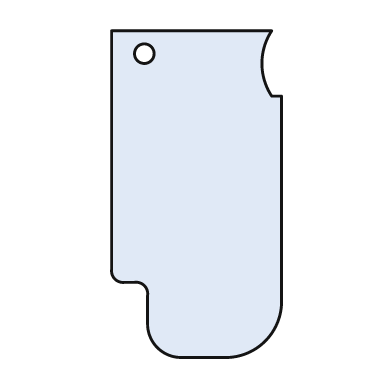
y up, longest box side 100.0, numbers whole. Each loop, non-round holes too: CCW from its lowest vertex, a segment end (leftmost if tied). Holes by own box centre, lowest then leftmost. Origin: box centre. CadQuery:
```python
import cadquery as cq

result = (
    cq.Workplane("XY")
    .moveTo(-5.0, -50.0)
    .lineTo(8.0, -50.0)
    .threePointArc((21.0, -45.0), (26.0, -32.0))
    .lineTo(26.0, 30.0)
    .lineTo(23.0, 30.0)
    .threePointArc((20.0, 40.0), (23.0, 50.0))
    .lineTo(-26.0, 50.0)
    .lineTo(-26.0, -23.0)
    .threePointArc((-25.0, -26.0), (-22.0, -27.0))
    .lineTo(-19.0, -27.0)
    .threePointArc((-16.0, -28.0), (-15.0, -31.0))
    .lineTo(-15.0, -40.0)
    .threePointArc((-12.0, -47.0), (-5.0, -50.0))
    .close()
    .moveTo(-16.0, 43.0)
    .circle(3.0)
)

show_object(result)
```